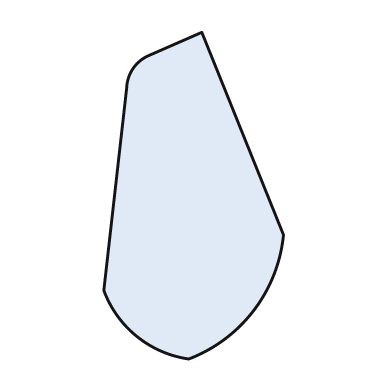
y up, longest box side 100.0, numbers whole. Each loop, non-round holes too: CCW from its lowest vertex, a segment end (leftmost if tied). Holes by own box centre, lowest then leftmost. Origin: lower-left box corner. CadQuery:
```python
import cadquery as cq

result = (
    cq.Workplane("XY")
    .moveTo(26.0, 0.0)
    .threePointArc((46.0, 15.0), (55.0, 38.0))
    .lineTo(30.0, 100.0)
    .lineTo(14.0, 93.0)
    .threePointArc((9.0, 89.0), (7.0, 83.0))
    .lineTo(0.0, 21.0)
    .threePointArc((10.0, 7.0), (26.0, 0.0))
    .close()
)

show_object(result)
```